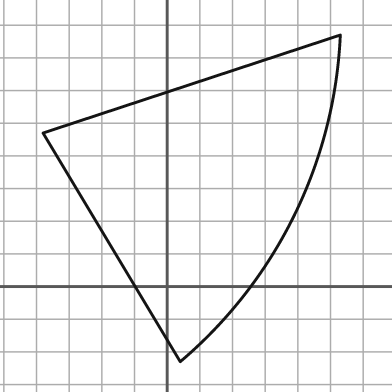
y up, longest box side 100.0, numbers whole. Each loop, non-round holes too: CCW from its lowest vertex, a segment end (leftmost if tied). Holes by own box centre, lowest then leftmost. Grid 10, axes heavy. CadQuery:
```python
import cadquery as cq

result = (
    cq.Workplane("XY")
    .moveTo(4.0, -23.0)
    .threePointArc((39.0, 22.0), (53.0, 77.0))
    .lineTo(-38.0, 47.0)
    .close()
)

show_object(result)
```